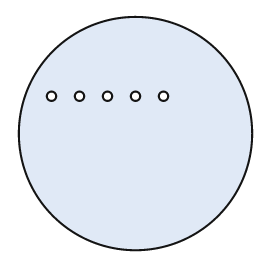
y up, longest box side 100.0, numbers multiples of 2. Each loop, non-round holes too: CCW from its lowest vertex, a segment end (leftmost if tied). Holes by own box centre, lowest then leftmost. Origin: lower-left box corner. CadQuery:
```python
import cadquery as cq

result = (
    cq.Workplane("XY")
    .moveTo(50.0, 50.0)
    .circle(50.0)
    .moveTo(14.0, 66.0)
    .circle(2.0)
    .moveTo(26.0, 66.0)
    .circle(2.0)
    .moveTo(38.0, 66.0)
    .circle(2.0)
    .moveTo(50.0, 66.0)
    .circle(2.0)
    .moveTo(62.0, 66.0)
    .circle(2.0)
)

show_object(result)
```